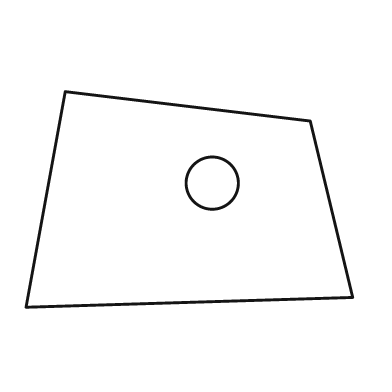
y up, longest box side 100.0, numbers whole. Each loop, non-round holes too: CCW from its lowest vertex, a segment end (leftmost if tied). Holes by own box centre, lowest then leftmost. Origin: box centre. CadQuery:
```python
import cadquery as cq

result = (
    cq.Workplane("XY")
    .moveTo(-50.0, -33.0)
    .lineTo(50.0, -30.0)
    .lineTo(37.0, 24.0)
    .lineTo(-38.0, 33.0)
    .close()
    .moveTo(7.0, 5.0)
    .circle(8.0)
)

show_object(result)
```